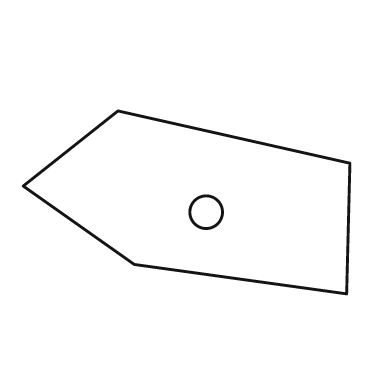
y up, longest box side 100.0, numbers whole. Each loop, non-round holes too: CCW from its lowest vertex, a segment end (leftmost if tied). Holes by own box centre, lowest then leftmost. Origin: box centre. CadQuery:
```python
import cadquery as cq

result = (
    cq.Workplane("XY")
    .moveTo(49.0, -28.0)
    .lineTo(50.0, 12.0)
    .lineTo(-21.0, 28.0)
    .lineTo(-50.0, 5.0)
    .lineTo(-16.0, -19.0)
    .close()
    .moveTo(6.0, -3.0)
    .circle(5.0)
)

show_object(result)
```